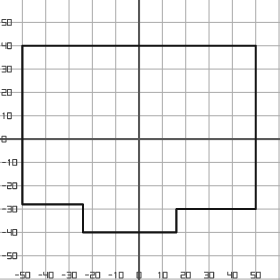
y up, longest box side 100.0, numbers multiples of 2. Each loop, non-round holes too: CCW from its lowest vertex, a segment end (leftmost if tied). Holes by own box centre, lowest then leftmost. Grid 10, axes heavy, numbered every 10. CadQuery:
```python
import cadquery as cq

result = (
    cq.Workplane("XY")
    .moveTo(-24.0, -40.0)
    .lineTo(16.0, -40.0)
    .lineTo(16.0, -30.0)
    .lineTo(50.0, -30.0)
    .lineTo(50.0, 40.0)
    .lineTo(-50.0, 40.0)
    .lineTo(-50.0, -28.0)
    .lineTo(-24.0, -28.0)
    .close()
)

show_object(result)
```